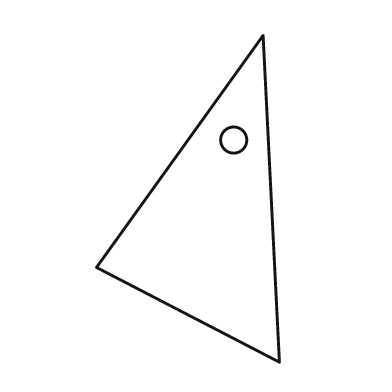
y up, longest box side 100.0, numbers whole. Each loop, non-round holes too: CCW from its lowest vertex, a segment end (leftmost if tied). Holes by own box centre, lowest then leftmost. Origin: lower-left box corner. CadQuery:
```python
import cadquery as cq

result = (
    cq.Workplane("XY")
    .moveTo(56.0, 0.0)
    .lineTo(51.0, 100.0)
    .lineTo(0.0, 29.0)
    .close()
    .moveTo(42.0, 68.0)
    .circle(4.0)
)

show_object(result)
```